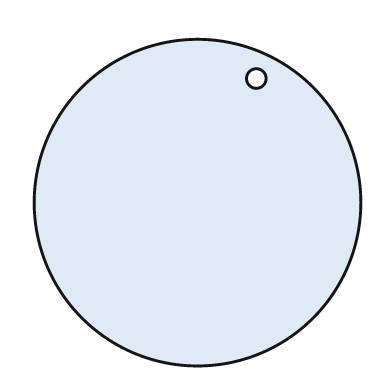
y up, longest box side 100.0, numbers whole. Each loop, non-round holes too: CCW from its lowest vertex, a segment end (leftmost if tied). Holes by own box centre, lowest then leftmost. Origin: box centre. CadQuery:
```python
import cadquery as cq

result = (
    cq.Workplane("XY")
    .moveTo(0.0, 0.0)
    .circle(50.0)
    .moveTo(18.0, 38.0)
    .circle(3.0)
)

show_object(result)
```